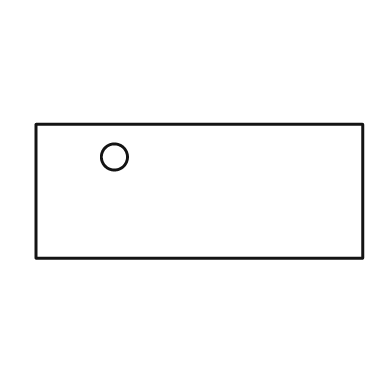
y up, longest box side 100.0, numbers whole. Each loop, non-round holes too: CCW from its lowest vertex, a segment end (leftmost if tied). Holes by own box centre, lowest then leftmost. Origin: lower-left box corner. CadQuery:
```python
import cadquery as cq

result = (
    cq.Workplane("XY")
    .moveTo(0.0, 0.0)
    .lineTo(100.0, 0.0)
    .lineTo(100.0, 41.0)
    .lineTo(0.0, 41.0)
    .close()
    .moveTo(24.0, 31.0)
    .circle(4.0)
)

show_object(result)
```